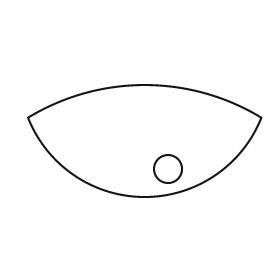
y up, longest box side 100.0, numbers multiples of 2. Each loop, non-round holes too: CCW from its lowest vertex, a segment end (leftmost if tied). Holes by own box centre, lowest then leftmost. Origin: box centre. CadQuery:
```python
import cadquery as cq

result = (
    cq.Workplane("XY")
    .moveTo(-50.0, 10.0)
    .threePointArc((0.0, -24.0), (50.0, 10.0))
    .threePointArc((0.0, 24.0), (-50.0, 10.0))
    .close()
    .moveTo(10.0, -12.0)
    .circle(6.0)
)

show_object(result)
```